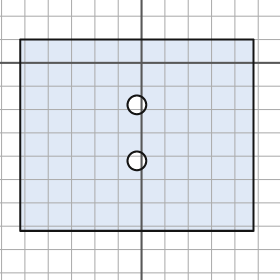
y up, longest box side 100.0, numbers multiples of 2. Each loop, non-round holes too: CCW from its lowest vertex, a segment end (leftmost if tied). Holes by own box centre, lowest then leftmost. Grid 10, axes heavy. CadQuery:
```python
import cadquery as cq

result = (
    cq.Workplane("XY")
    .moveTo(-52.0, -72.0)
    .lineTo(48.0, -72.0)
    .lineTo(48.0, 10.0)
    .lineTo(-52.0, 10.0)
    .close()
    .moveTo(-2.0, -42.0)
    .circle(4.0)
    .moveTo(-2.0, -18.0)
    .circle(4.0)
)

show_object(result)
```